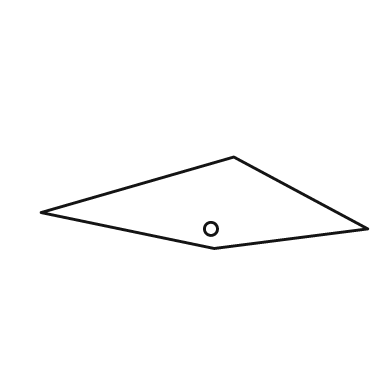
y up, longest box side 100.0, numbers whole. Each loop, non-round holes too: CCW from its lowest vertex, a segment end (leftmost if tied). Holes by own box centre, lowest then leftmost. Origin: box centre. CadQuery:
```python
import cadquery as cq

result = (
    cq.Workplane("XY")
    .moveTo(3.0, -14.0)
    .lineTo(50.0, -8.0)
    .lineTo(9.0, 14.0)
    .lineTo(-50.0, -3.0)
    .close()
    .moveTo(2.0, -8.0)
    .circle(2.0)
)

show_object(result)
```